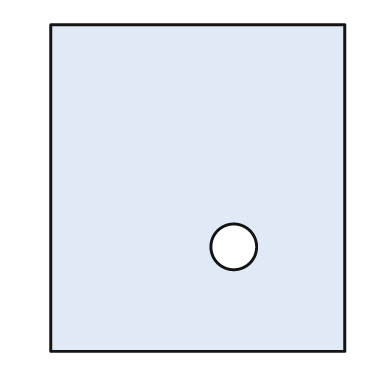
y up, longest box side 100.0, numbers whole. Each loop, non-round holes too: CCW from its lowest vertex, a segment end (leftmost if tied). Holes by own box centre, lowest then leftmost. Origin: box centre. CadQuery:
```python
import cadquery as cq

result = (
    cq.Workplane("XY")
    .moveTo(-45.0, -50.0)
    .lineTo(45.0, -50.0)
    .lineTo(45.0, 50.0)
    .lineTo(-45.0, 50.0)
    .close()
    .moveTo(11.0, -18.0)
    .circle(7.0)
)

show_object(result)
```